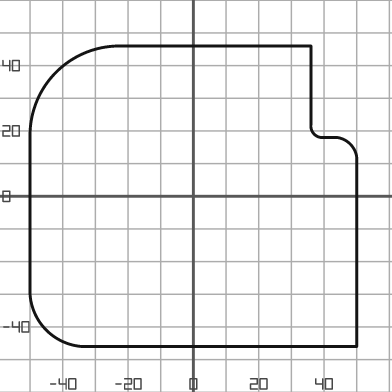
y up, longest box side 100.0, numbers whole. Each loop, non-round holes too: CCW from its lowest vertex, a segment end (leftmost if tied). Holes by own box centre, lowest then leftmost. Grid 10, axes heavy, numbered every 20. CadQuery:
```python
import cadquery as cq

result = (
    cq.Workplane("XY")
    .moveTo(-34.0, -46.0)
    .lineTo(50.0, -46.0)
    .lineTo(50.0, 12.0)
    .threePointArc((48.0, 16.0), (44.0, 18.0))
    .lineTo(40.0, 18.0)
    .threePointArc((37.0, 19.0), (36.0, 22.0))
    .lineTo(36.0, 46.0)
    .lineTo(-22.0, 46.0)
    .threePointArc((-42.0, 38.0), (-50.0, 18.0))
    .lineTo(-50.0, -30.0)
    .threePointArc((-45.0, -41.0), (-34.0, -46.0))
    .close()
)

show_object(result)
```